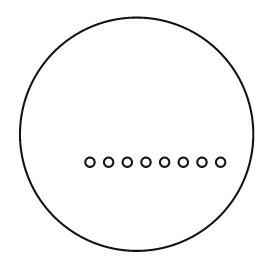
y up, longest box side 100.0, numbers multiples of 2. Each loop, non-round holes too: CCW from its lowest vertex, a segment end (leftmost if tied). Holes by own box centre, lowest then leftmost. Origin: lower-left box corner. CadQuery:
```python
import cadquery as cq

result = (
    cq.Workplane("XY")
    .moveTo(50.0, 50.0)
    .circle(50.0)
    .moveTo(30.0, 38.0)
    .circle(2.0)
    .moveTo(38.0, 38.0)
    .circle(2.0)
    .moveTo(46.0, 38.0)
    .circle(2.0)
    .moveTo(54.0, 38.0)
    .circle(2.0)
    .moveTo(62.0, 38.0)
    .circle(2.0)
    .moveTo(70.0, 38.0)
    .circle(2.0)
    .moveTo(78.0, 38.0)
    .circle(2.0)
    .moveTo(86.0, 38.0)
    .circle(2.0)
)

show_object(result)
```